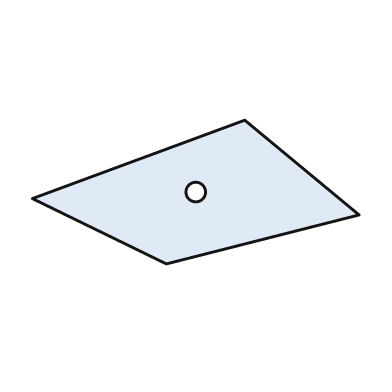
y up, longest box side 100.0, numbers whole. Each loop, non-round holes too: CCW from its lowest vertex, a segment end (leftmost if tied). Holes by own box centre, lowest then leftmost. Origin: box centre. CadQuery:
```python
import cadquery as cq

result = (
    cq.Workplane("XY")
    .moveTo(-9.0, -22.0)
    .lineTo(50.0, -7.0)
    .lineTo(15.0, 22.0)
    .lineTo(-50.0, -2.0)
    .close()
    .moveTo(0.0, 0.0)
    .circle(3.0)
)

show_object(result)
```